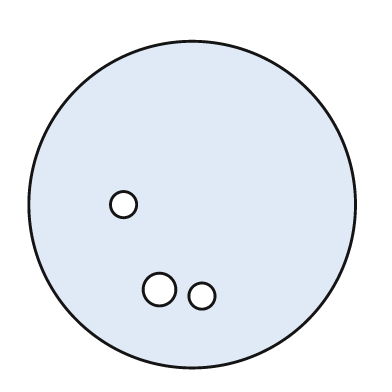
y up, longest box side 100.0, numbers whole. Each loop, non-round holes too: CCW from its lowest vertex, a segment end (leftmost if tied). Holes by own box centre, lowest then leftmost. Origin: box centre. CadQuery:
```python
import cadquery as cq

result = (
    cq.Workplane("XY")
    .moveTo(0.0, 0.0)
    .circle(50.0)
    .moveTo(3.0, -28.0)
    .circle(4.0)
    .moveTo(-10.0, -26.0)
    .circle(5.0)
    .moveTo(-21.0, 0.0)
    .circle(4.0)
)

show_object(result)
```